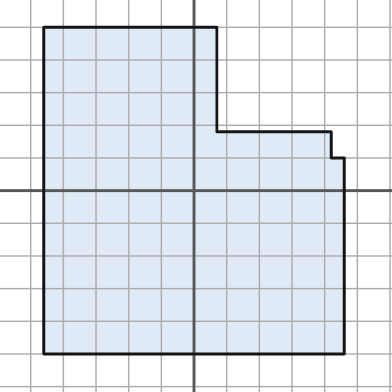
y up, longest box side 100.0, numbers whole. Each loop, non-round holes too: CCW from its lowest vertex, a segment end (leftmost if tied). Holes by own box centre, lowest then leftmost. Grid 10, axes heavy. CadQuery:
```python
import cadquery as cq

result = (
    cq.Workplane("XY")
    .moveTo(-46.0, -50.0)
    .lineTo(46.0, -50.0)
    .lineTo(46.0, 10.0)
    .lineTo(42.0, 10.0)
    .lineTo(42.0, 18.0)
    .lineTo(7.0, 18.0)
    .lineTo(7.0, 50.0)
    .lineTo(-46.0, 50.0)
    .close()
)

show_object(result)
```